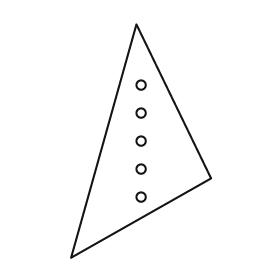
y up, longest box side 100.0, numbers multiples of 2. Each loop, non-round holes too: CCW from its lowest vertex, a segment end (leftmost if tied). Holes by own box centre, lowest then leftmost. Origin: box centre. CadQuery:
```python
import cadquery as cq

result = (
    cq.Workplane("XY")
    .moveTo(-30.0, -50.0)
    .lineTo(30.0, -16.0)
    .lineTo(-2.0, 50.0)
    .close()
    .moveTo(0.0, -24.0)
    .circle(2.0)
    .moveTo(0.0, -12.0)
    .circle(2.0)
    .moveTo(0.0, 0.0)
    .circle(2.0)
    .moveTo(0.0, 12.0)
    .circle(2.0)
    .moveTo(0.0, 24.0)
    .circle(2.0)
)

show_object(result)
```